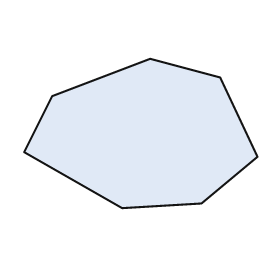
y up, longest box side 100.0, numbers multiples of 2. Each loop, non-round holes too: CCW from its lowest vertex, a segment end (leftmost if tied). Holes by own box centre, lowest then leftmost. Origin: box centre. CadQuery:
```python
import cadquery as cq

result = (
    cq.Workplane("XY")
    .moveTo(-8.0, -32.0)
    .lineTo(26.0, -30.0)
    .lineTo(50.0, -10.0)
    .lineTo(34.0, 24.0)
    .lineTo(4.0, 32.0)
    .lineTo(-38.0, 16.0)
    .lineTo(-50.0, -8.0)
    .close()
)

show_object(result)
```